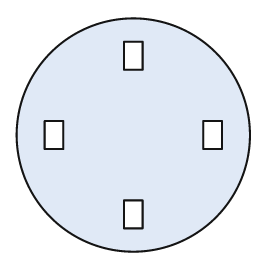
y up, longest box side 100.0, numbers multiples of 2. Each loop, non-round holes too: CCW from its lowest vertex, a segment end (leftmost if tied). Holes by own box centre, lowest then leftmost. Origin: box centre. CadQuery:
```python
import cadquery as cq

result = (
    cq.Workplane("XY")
    .moveTo(0.0, 0.0)
    .circle(50.0)
    .moveTo(-4.0, -40.0)
    .lineTo(4.0, -40.0)
    .lineTo(4.0, -28.0)
    .lineTo(-4.0, -28.0)
    .close()
    .moveTo(-38.0, -6.0)
    .lineTo(-30.0, -6.0)
    .lineTo(-30.0, 6.0)
    .lineTo(-38.0, 6.0)
    .close()
    .moveTo(30.0, -6.0)
    .lineTo(38.0, -6.0)
    .lineTo(38.0, 6.0)
    .lineTo(30.0, 6.0)
    .close()
    .moveTo(-4.0, 28.0)
    .lineTo(4.0, 28.0)
    .lineTo(4.0, 40.0)
    .lineTo(-4.0, 40.0)
    .close()
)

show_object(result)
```